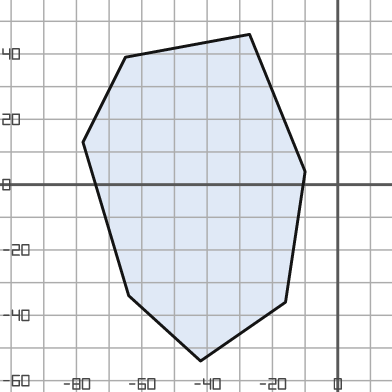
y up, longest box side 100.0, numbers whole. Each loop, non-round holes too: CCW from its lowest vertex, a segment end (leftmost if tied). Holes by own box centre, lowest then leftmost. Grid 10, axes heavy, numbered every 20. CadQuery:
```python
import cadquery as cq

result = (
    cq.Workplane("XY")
    .moveTo(-42.0, -54.0)
    .lineTo(-16.0, -36.0)
    .lineTo(-10.0, 4.0)
    .lineTo(-27.0, 46.0)
    .lineTo(-65.0, 39.0)
    .lineTo(-78.0, 13.0)
    .lineTo(-64.0, -34.0)
    .close()
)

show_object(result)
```